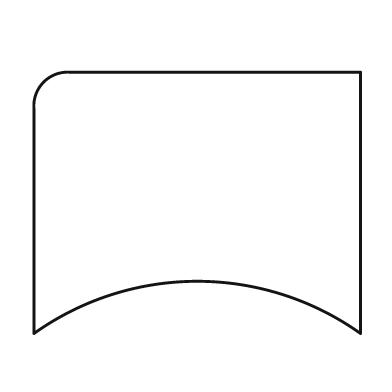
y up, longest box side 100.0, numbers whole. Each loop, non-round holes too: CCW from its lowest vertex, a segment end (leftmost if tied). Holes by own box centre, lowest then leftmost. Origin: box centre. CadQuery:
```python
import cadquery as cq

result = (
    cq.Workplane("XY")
    .moveTo(-50.0, -40.0)
    .threePointArc((0.0, -24.0), (50.0, -40.0))
    .lineTo(50.0, 40.0)
    .lineTo(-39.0, 40.0)
    .threePointArc((-47.0, 37.0), (-50.0, 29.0))
    .close()
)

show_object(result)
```